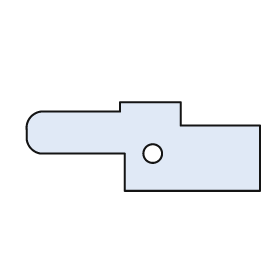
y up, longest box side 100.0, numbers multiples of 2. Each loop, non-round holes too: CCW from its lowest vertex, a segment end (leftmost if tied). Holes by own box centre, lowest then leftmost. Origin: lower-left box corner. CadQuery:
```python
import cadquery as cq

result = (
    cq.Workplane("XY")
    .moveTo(42.0, 0.0)
    .lineTo(100.0, 0.0)
    .lineTo(100.0, 28.0)
    .lineTo(66.0, 28.0)
    .lineTo(66.0, 38.0)
    .lineTo(40.0, 38.0)
    .lineTo(40.0, 34.0)
    .lineTo(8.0, 34.0)
    .threePointArc((2.0, 32.0), (0.0, 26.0))
    .lineTo(0.0, 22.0)
    .threePointArc((2.0, 18.0), (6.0, 16.0))
    .lineTo(42.0, 16.0)
    .close()
    .moveTo(54.0, 16.0)
    .circle(4.0)
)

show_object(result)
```